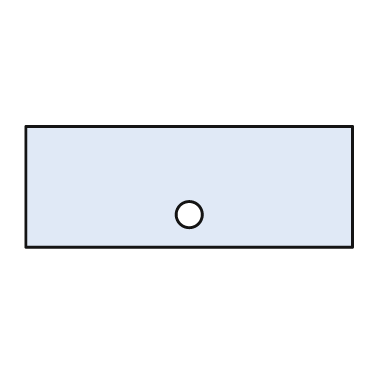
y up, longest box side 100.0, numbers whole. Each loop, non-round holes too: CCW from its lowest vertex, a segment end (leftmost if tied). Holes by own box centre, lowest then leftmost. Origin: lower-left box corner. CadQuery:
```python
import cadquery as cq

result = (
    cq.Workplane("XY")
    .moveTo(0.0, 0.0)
    .lineTo(100.0, 0.0)
    .lineTo(100.0, 37.0)
    .lineTo(0.0, 37.0)
    .close()
    .moveTo(50.0, 10.0)
    .circle(4.0)
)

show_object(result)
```